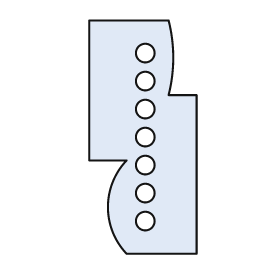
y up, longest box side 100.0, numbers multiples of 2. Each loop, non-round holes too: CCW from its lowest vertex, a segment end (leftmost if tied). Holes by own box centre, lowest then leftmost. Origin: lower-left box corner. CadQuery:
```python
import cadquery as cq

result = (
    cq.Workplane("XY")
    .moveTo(16.0, 0.0)
    .lineTo(46.0, 0.0)
    .lineTo(46.0, 68.0)
    .lineTo(34.0, 68.0)
    .threePointArc((36.0, 84.0), (34.0, 100.0))
    .lineTo(0.0, 100.0)
    .lineTo(0.0, 40.0)
    .lineTo(16.0, 40.0)
    .threePointArc((8.0, 20.0), (16.0, 0.0))
    .close()
    .moveTo(24.0, 14.0)
    .circle(4.0)
    .moveTo(24.0, 26.0)
    .circle(4.0)
    .moveTo(24.0, 38.0)
    .circle(4.0)
    .moveTo(24.0, 50.0)
    .circle(4.0)
    .moveTo(24.0, 62.0)
    .circle(4.0)
    .moveTo(24.0, 74.0)
    .circle(4.0)
    .moveTo(24.0, 86.0)
    .circle(4.0)
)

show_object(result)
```